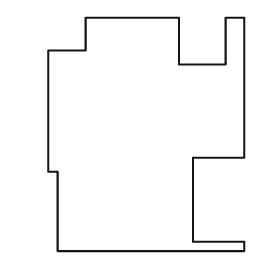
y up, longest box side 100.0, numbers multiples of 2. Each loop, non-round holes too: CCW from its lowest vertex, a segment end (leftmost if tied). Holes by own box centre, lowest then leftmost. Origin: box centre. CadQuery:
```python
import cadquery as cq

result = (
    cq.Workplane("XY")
    .moveTo(-38.0, -50.0)
    .lineTo(42.0, -50.0)
    .lineTo(42.0, -46.0)
    .lineTo(20.0, -46.0)
    .lineTo(20.0, -10.0)
    .lineTo(42.0, -10.0)
    .lineTo(42.0, 50.0)
    .lineTo(34.0, 50.0)
    .lineTo(34.0, 30.0)
    .lineTo(14.0, 30.0)
    .lineTo(14.0, 50.0)
    .lineTo(-26.0, 50.0)
    .lineTo(-26.0, 36.0)
    .lineTo(-42.0, 36.0)
    .lineTo(-42.0, -16.0)
    .lineTo(-38.0, -16.0)
    .close()
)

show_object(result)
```